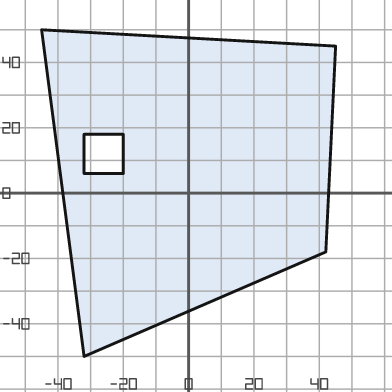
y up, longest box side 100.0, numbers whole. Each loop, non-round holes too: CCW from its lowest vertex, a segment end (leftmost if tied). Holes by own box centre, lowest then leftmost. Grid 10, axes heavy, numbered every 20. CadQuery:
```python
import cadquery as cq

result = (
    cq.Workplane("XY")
    .moveTo(-32.0, -50.0)
    .lineTo(42.0, -18.0)
    .lineTo(45.0, 45.0)
    .lineTo(-45.0, 50.0)
    .close()
    .moveTo(-32.0, 6.0)
    .lineTo(-20.0, 6.0)
    .lineTo(-20.0, 18.0)
    .lineTo(-32.0, 18.0)
    .close()
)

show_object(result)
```